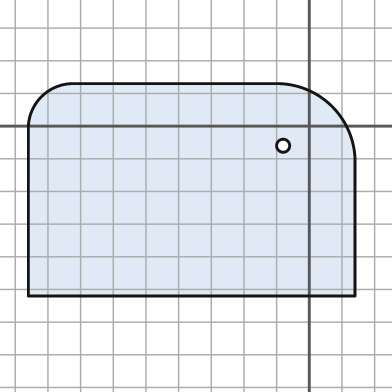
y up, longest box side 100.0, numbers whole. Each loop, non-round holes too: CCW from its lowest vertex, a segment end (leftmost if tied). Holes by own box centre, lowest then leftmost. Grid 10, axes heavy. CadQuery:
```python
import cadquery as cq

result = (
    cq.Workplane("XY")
    .moveTo(-86.0, -52.0)
    .lineTo(14.0, -52.0)
    .lineTo(14.0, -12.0)
    .threePointArc((7.0, 6.0), (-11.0, 13.0))
    .lineTo(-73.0, 13.0)
    .threePointArc((-82.0, 9.0), (-86.0, 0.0))
    .close()
    .moveTo(-8.0, -6.0)
    .circle(2.0)
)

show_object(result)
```